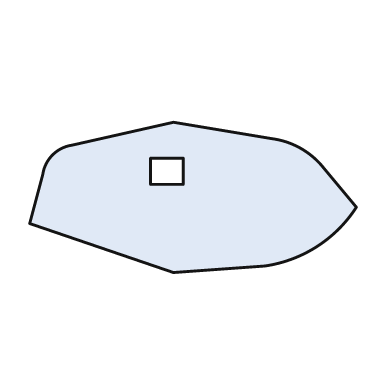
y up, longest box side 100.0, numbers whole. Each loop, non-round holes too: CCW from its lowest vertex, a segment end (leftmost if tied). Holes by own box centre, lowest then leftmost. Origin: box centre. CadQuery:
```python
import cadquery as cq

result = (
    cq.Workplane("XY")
    .moveTo(-6.0, -23.0)
    .lineTo(22.0, -21.0)
    .threePointArc((38.0, -15.0), (50.0, -3.0))
    .lineTo(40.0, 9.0)
    .threePointArc((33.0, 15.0), (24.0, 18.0))
    .lineTo(-6.0, 23.0)
    .lineTo(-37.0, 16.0)
    .threePointArc((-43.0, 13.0), (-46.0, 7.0))
    .lineTo(-50.0, -8.0)
    .close()
    .moveTo(-13.0, 4.0)
    .lineTo(-3.0, 4.0)
    .lineTo(-3.0, 12.0)
    .lineTo(-13.0, 12.0)
    .close()
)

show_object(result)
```